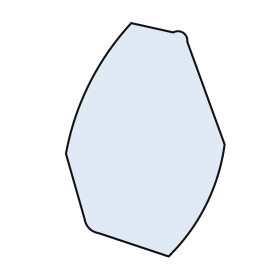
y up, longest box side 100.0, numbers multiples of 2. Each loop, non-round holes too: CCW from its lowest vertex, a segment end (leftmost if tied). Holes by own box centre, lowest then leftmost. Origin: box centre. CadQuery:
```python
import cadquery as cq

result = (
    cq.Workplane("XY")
    .moveTo(10.0, -50.0)
    .threePointArc((26.0, -28.0), (34.0, -2.0))
    .lineTo(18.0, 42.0)
    .threePointArc((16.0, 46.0), (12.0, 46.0))
    .lineTo(-6.0, 50.0)
    .threePointArc((-24.0, 24.0), (-34.0, -6.0))
    .lineTo(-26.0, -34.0)
    .threePointArc((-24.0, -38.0), (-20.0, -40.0))
    .close()
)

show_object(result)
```